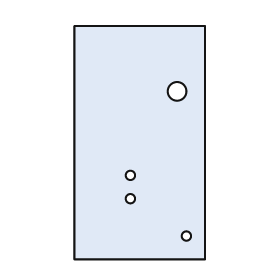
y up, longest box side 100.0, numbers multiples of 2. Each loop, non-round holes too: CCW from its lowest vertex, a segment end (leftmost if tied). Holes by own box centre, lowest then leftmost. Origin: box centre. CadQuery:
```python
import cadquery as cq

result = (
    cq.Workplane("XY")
    .moveTo(-28.0, -50.0)
    .lineTo(28.0, -50.0)
    .lineTo(28.0, 50.0)
    .lineTo(-28.0, 50.0)
    .close()
    .moveTo(20.0, -40.0)
    .circle(2.0)
    .moveTo(-4.0, -24.0)
    .circle(2.0)
    .moveTo(-4.0, -14.0)
    .circle(2.0)
    .moveTo(16.0, 22.0)
    .circle(4.0)
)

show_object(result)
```